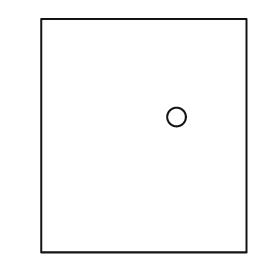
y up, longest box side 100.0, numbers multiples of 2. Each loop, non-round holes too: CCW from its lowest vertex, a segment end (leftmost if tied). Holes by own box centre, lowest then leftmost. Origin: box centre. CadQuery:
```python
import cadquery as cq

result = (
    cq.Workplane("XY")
    .moveTo(-44.0, -50.0)
    .lineTo(44.0, -50.0)
    .lineTo(44.0, 50.0)
    .lineTo(-44.0, 50.0)
    .close()
    .moveTo(14.0, 8.0)
    .circle(4.0)
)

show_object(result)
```